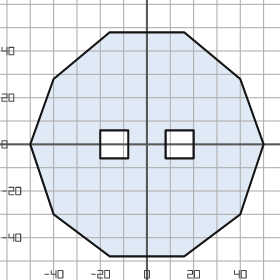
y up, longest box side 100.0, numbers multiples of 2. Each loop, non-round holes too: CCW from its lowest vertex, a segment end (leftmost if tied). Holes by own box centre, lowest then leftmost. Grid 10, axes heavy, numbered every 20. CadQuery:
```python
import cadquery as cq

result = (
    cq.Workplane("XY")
    .moveTo(-16.0, -48.0)
    .lineTo(16.0, -48.0)
    .lineTo(40.0, -30.0)
    .lineTo(50.0, 0.0)
    .lineTo(40.0, 28.0)
    .lineTo(16.0, 48.0)
    .lineTo(-16.0, 48.0)
    .lineTo(-40.0, 28.0)
    .lineTo(-50.0, 0.0)
    .lineTo(-40.0, -30.0)
    .close()
    .moveTo(-20.0, -6.0)
    .lineTo(-8.0, -6.0)
    .lineTo(-8.0, 6.0)
    .lineTo(-20.0, 6.0)
    .close()
    .moveTo(8.0, -6.0)
    .lineTo(20.0, -6.0)
    .lineTo(20.0, 6.0)
    .lineTo(8.0, 6.0)
    .close()
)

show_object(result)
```